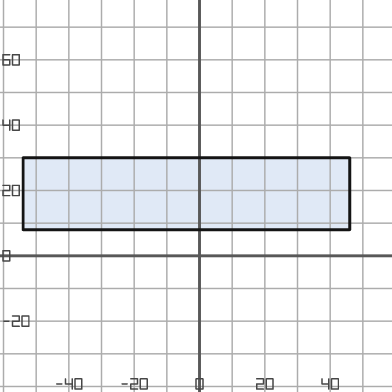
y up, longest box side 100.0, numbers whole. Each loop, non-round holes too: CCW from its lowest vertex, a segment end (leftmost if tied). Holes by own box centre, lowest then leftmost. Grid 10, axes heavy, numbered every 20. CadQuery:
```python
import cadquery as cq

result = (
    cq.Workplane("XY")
    .moveTo(-54.0, 8.0)
    .lineTo(46.0, 8.0)
    .lineTo(46.0, 30.0)
    .lineTo(-54.0, 30.0)
    .close()
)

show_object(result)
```